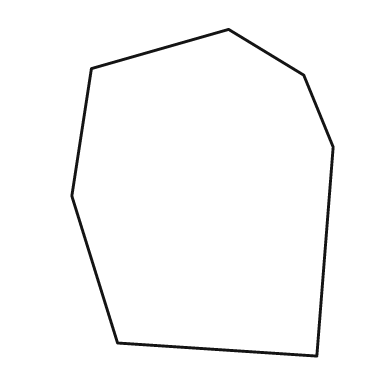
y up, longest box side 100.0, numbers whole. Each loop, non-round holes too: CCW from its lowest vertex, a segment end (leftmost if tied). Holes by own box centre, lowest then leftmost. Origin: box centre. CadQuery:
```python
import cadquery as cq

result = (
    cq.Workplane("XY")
    .moveTo(35.0, -50.0)
    .lineTo(40.0, 14.0)
    .lineTo(31.0, 36.0)
    .lineTo(8.0, 50.0)
    .lineTo(-34.0, 38.0)
    .lineTo(-40.0, -1.0)
    .lineTo(-26.0, -46.0)
    .close()
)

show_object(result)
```